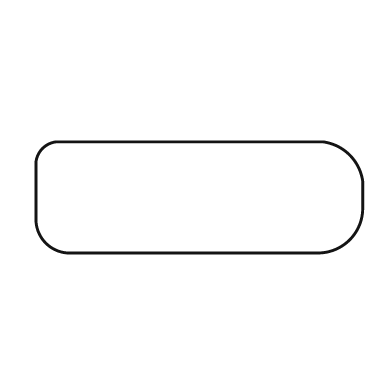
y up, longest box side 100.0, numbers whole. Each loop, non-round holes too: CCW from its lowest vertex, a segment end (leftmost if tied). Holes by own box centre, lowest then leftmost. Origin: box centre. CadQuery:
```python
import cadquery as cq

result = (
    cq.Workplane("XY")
    .moveTo(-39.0, -17.0)
    .lineTo(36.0, -17.0)
    .threePointArc((46.0, -13.0), (50.0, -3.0))
    .lineTo(50.0, 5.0)
    .threePointArc((46.0, 13.0), (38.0, 17.0))
    .lineTo(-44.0, 17.0)
    .threePointArc((-48.0, 15.0), (-50.0, 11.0))
    .lineTo(-50.0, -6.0)
    .threePointArc((-47.0, -14.0), (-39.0, -17.0))
    .close()
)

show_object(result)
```